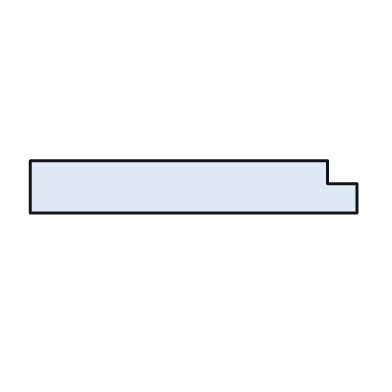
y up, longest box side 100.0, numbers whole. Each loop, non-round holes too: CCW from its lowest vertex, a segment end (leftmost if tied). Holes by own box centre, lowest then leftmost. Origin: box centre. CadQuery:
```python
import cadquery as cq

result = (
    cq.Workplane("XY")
    .moveTo(-50.0, -8.0)
    .lineTo(50.0, -8.0)
    .lineTo(50.0, 1.0)
    .lineTo(41.0, 1.0)
    .lineTo(41.0, 8.0)
    .lineTo(-50.0, 8.0)
    .close()
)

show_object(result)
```